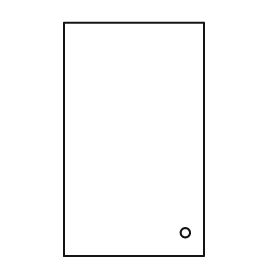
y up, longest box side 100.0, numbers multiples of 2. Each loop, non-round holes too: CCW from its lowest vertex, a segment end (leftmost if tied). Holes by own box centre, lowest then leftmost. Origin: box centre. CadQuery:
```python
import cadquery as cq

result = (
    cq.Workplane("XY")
    .moveTo(-30.0, -50.0)
    .lineTo(30.0, -50.0)
    .lineTo(30.0, 50.0)
    .lineTo(-30.0, 50.0)
    .close()
    .moveTo(22.0, -40.0)
    .circle(2.0)
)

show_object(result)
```